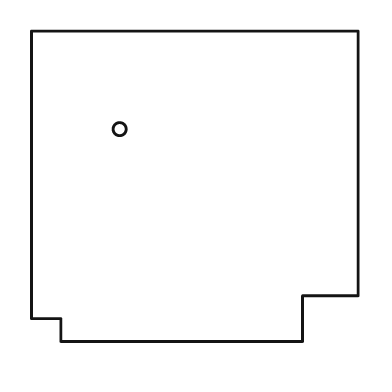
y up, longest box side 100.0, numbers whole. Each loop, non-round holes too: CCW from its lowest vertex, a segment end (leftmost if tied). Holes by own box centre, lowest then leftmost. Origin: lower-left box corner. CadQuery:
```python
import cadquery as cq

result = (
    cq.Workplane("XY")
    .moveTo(9.0, 0.0)
    .lineTo(83.0, 0.0)
    .lineTo(83.0, 14.0)
    .lineTo(100.0, 14.0)
    .lineTo(100.0, 95.0)
    .lineTo(0.0, 95.0)
    .lineTo(0.0, 7.0)
    .lineTo(9.0, 7.0)
    .close()
    .moveTo(27.0, 65.0)
    .circle(2.0)
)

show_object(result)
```